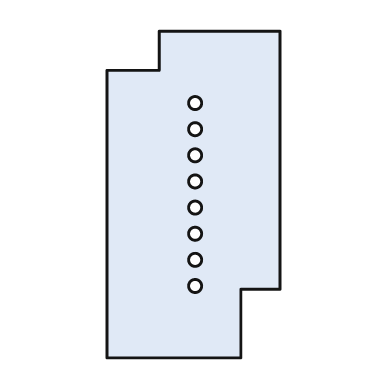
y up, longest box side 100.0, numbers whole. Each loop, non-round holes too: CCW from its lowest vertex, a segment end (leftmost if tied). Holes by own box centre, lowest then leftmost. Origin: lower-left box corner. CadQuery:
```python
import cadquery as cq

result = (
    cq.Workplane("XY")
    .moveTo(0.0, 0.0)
    .lineTo(41.0, 0.0)
    .lineTo(41.0, 21.0)
    .lineTo(53.0, 21.0)
    .lineTo(53.0, 100.0)
    .lineTo(16.0, 100.0)
    .lineTo(16.0, 88.0)
    .lineTo(0.0, 88.0)
    .close()
    .moveTo(27.0, 22.0)
    .circle(2.0)
    .moveTo(27.0, 30.0)
    .circle(2.0)
    .moveTo(27.0, 38.0)
    .circle(2.0)
    .moveTo(27.0, 46.0)
    .circle(2.0)
    .moveTo(27.0, 54.0)
    .circle(2.0)
    .moveTo(27.0, 62.0)
    .circle(2.0)
    .moveTo(27.0, 70.0)
    .circle(2.0)
    .moveTo(27.0, 78.0)
    .circle(2.0)
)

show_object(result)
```